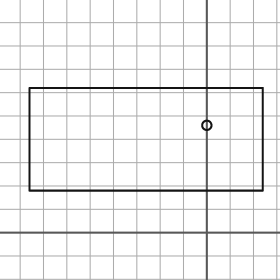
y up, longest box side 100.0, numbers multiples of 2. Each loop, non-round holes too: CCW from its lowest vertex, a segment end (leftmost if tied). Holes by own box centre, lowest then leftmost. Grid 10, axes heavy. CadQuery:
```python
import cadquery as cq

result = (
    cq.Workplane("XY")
    .moveTo(-76.0, 18.0)
    .lineTo(24.0, 18.0)
    .lineTo(24.0, 62.0)
    .lineTo(-76.0, 62.0)
    .close()
    .moveTo(0.0, 46.0)
    .circle(2.0)
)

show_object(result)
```